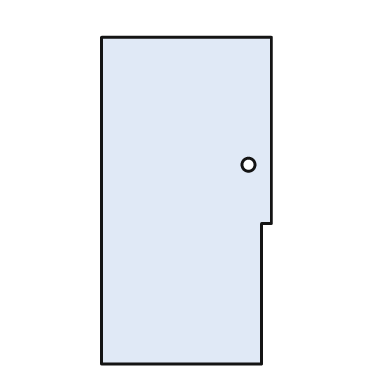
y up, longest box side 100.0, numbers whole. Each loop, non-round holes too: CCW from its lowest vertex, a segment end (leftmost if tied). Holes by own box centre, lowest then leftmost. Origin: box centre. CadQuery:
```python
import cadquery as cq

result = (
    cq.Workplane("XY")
    .moveTo(-26.0, -50.0)
    .lineTo(23.0, -50.0)
    .lineTo(23.0, -7.0)
    .lineTo(26.0, -7.0)
    .lineTo(26.0, 50.0)
    .lineTo(-26.0, 50.0)
    .close()
    .moveTo(19.0, 11.0)
    .circle(2.0)
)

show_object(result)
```